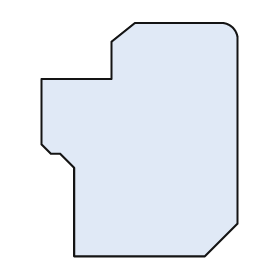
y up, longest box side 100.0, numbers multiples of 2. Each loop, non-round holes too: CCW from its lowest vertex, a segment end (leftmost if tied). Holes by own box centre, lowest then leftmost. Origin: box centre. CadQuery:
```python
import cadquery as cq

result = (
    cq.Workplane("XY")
    .moveTo(-28.0, -50.0)
    .lineTo(28.0, -50.0)
    .lineTo(42.0, -36.0)
    .lineTo(42.0, 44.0)
    .threePointArc((40.0, 48.0), (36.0, 50.0))
    .lineTo(-2.0, 50.0)
    .lineTo(-12.0, 42.0)
    .lineTo(-12.0, 26.0)
    .lineTo(-42.0, 26.0)
    .lineTo(-42.0, -2.0)
    .lineTo(-38.0, -6.0)
    .lineTo(-34.0, -6.0)
    .lineTo(-28.0, -12.0)
    .close()
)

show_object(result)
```